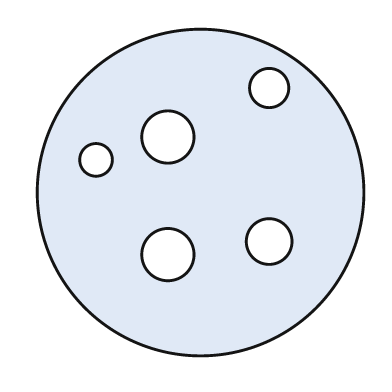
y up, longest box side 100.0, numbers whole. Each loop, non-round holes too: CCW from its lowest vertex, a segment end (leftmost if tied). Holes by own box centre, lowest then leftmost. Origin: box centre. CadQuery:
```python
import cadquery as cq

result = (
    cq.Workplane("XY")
    .moveTo(0.0, 0.0)
    .circle(50.0)
    .moveTo(-10.0, -19.0)
    .circle(8.0)
    .moveTo(21.0, -15.0)
    .circle(7.0)
    .moveTo(-32.0, 10.0)
    .circle(5.0)
    .moveTo(-10.0, 17.0)
    .circle(8.0)
    .moveTo(21.0, 32.0)
    .circle(6.0)
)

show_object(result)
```